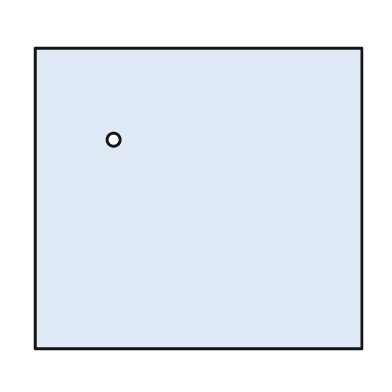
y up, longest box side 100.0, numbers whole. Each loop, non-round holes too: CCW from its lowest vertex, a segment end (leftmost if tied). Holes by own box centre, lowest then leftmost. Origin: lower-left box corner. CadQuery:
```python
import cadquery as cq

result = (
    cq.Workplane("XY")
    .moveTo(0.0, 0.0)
    .lineTo(100.0, 0.0)
    .lineTo(100.0, 92.0)
    .lineTo(0.0, 92.0)
    .close()
    .moveTo(24.0, 64.0)
    .circle(2.0)
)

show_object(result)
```